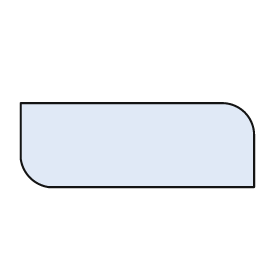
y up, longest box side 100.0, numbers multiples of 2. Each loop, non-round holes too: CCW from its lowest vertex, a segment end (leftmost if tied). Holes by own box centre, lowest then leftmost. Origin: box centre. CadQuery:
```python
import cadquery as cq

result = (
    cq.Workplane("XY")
    .moveTo(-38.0, -18.0)
    .lineTo(50.0, -18.0)
    .lineTo(50.0, 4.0)
    .threePointArc((46.0, 14.0), (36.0, 18.0))
    .lineTo(-50.0, 18.0)
    .lineTo(-50.0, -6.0)
    .threePointArc((-46.0, -14.0), (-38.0, -18.0))
    .close()
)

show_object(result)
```